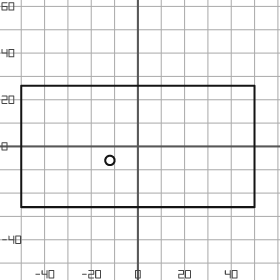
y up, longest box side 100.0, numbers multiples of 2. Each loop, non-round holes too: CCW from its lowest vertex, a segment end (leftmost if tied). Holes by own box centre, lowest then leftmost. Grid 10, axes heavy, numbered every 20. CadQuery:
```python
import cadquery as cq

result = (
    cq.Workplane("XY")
    .moveTo(-50.0, -26.0)
    .lineTo(50.0, -26.0)
    .lineTo(50.0, 26.0)
    .lineTo(-50.0, 26.0)
    .close()
    .moveTo(-12.0, -6.0)
    .circle(2.0)
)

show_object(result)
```